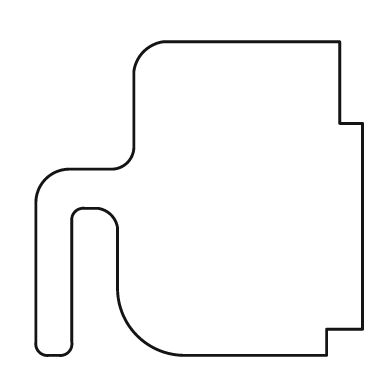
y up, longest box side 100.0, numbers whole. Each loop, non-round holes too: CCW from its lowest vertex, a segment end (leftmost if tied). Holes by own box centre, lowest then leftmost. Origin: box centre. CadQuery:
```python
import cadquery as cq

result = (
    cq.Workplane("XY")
    .moveTo(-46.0, -48.0)
    .lineTo(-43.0, -48.0)
    .threePointArc((-40.0, -47.0), (-39.0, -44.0))
    .lineTo(-39.0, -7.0)
    .threePointArc((-38.0, -4.0), (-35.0, -3.0))
    .lineTo(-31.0, -3.0)
    .threePointArc((-27.0, -5.0), (-25.0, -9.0))
    .lineTo(-25.0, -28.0)
    .threePointArc((-19.0, -42.0), (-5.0, -48.0))
    .lineTo(39.0, -48.0)
    .lineTo(39.0, -40.0)
    .lineTo(50.0, -40.0)
    .lineTo(50.0, 23.0)
    .lineTo(43.0, 23.0)
    .lineTo(43.0, 48.0)
    .lineTo(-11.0, 48.0)
    .threePointArc((-17.0, 45.0), (-20.0, 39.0))
    .lineTo(-20.0, 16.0)
    .threePointArc((-22.0, 11.0), (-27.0, 9.0))
    .lineTo(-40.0, 9.0)
    .threePointArc((-47.0, 6.0), (-50.0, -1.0))
    .lineTo(-50.0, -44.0)
    .threePointArc((-49.0, -47.0), (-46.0, -48.0))
    .close()
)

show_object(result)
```